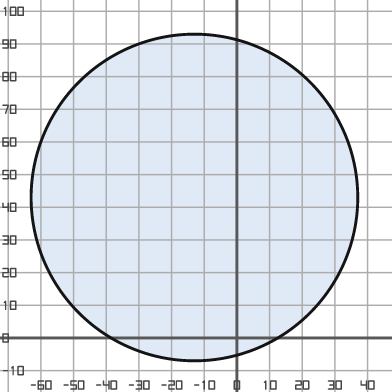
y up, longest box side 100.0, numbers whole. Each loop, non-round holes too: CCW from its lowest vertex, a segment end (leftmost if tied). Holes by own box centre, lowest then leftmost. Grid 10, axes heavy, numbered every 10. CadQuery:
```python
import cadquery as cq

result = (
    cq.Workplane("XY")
    .moveTo(-13.0, 43.0)
    .circle(50.0)
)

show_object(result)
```